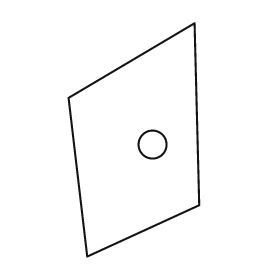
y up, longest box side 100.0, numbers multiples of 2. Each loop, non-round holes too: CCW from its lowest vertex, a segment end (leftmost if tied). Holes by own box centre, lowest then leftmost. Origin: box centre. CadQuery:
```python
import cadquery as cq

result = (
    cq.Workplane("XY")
    .moveTo(-20.0, -50.0)
    .lineTo(28.0, -28.0)
    .lineTo(26.0, 50.0)
    .lineTo(-28.0, 18.0)
    .close()
    .moveTo(8.0, -2.0)
    .circle(6.0)
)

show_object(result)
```